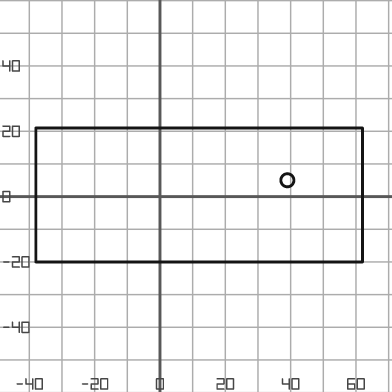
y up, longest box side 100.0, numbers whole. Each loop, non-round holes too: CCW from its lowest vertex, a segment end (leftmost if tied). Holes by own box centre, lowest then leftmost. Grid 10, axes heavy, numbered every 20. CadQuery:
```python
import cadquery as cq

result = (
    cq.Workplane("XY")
    .moveTo(-38.0, -20.0)
    .lineTo(62.0, -20.0)
    .lineTo(62.0, 21.0)
    .lineTo(-38.0, 21.0)
    .close()
    .moveTo(39.0, 5.0)
    .circle(2.0)
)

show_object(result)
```